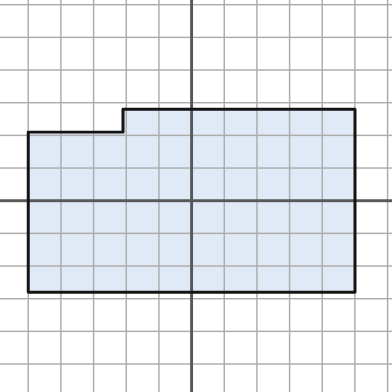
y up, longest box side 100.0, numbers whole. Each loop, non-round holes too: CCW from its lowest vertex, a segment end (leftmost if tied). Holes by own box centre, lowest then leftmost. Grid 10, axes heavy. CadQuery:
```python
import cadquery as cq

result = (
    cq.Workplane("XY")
    .moveTo(-50.0, -28.0)
    .lineTo(50.0, -28.0)
    .lineTo(50.0, 28.0)
    .lineTo(-21.0, 28.0)
    .lineTo(-21.0, 21.0)
    .lineTo(-50.0, 21.0)
    .close()
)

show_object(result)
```